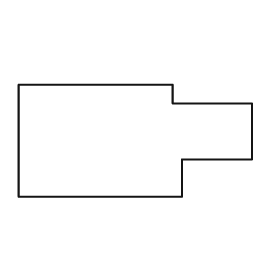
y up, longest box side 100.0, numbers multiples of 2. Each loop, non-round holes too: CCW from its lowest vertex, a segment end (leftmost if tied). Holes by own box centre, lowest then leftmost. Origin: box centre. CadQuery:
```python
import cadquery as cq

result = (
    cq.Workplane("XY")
    .moveTo(-50.0, -24.0)
    .lineTo(20.0, -24.0)
    .lineTo(20.0, -8.0)
    .lineTo(50.0, -8.0)
    .lineTo(50.0, 16.0)
    .lineTo(16.0, 16.0)
    .lineTo(16.0, 24.0)
    .lineTo(-50.0, 24.0)
    .close()
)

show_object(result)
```